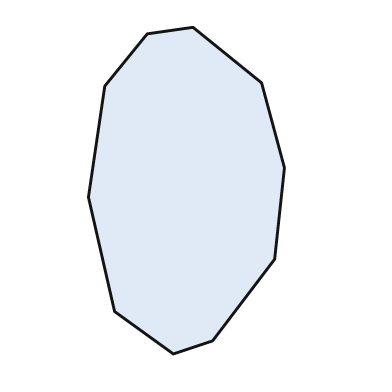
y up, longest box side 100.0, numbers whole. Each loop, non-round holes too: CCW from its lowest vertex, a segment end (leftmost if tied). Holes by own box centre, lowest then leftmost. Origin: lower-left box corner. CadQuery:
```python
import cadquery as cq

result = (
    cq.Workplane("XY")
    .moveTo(26.0, 0.0)
    .lineTo(38.0, 4.0)
    .lineTo(57.0, 29.0)
    .lineTo(60.0, 57.0)
    .lineTo(53.0, 83.0)
    .lineTo(32.0, 100.0)
    .lineTo(18.0, 98.0)
    .lineTo(5.0, 82.0)
    .lineTo(0.0, 48.0)
    .lineTo(8.0, 13.0)
    .close()
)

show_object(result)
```